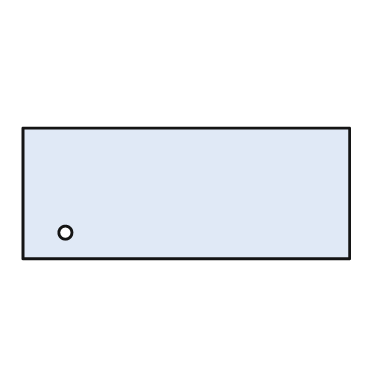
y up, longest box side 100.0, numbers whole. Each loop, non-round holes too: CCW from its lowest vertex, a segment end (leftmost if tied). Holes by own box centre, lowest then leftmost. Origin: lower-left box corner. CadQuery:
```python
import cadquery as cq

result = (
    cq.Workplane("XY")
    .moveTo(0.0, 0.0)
    .lineTo(100.0, 0.0)
    .lineTo(100.0, 40.0)
    .lineTo(0.0, 40.0)
    .close()
    .moveTo(13.0, 8.0)
    .circle(2.0)
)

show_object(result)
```